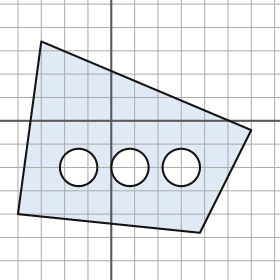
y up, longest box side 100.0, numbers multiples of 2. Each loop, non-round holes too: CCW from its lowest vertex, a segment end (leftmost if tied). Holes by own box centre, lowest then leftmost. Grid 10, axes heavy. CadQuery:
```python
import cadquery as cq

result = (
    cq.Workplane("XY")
    .moveTo(38.0, -48.0)
    .lineTo(60.0, -4.0)
    .lineTo(-30.0, 34.0)
    .lineTo(-40.0, -40.0)
    .close()
    .moveTo(-14.0, -20.0)
    .circle(8.0)
    .moveTo(8.0, -20.0)
    .circle(8.0)
    .moveTo(30.0, -20.0)
    .circle(8.0)
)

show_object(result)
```